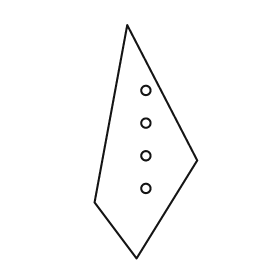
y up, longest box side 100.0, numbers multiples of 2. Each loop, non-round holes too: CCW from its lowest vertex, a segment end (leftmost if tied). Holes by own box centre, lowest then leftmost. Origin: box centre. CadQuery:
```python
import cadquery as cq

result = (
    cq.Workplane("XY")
    .moveTo(-4.0, -50.0)
    .lineTo(22.0, -8.0)
    .lineTo(-8.0, 50.0)
    .lineTo(-22.0, -26.0)
    .close()
    .moveTo(0.0, -20.0)
    .circle(2.0)
    .moveTo(0.0, -6.0)
    .circle(2.0)
    .moveTo(0.0, 8.0)
    .circle(2.0)
    .moveTo(0.0, 22.0)
    .circle(2.0)
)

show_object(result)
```